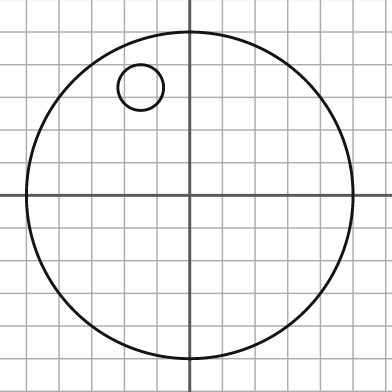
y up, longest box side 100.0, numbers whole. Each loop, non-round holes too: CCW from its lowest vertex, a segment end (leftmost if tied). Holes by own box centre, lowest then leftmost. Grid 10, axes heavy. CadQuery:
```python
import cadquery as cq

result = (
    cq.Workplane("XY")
    .moveTo(0.0, 0.0)
    .circle(50.0)
    .moveTo(-15.0, 33.0)
    .circle(7.0)
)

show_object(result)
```